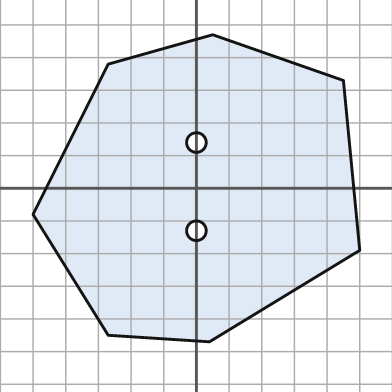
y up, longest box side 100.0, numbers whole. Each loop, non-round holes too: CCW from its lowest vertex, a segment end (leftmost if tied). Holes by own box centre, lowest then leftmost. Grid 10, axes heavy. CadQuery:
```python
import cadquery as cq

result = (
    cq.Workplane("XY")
    .moveTo(4.0, -47.0)
    .lineTo(50.0, -19.0)
    .lineTo(45.0, 33.0)
    .lineTo(5.0, 47.0)
    .lineTo(-27.0, 38.0)
    .lineTo(-50.0, -8.0)
    .lineTo(-27.0, -45.0)
    .close()
    .moveTo(0.0, -13.0)
    .circle(3.0)
    .moveTo(0.0, 14.0)
    .circle(3.0)
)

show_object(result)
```